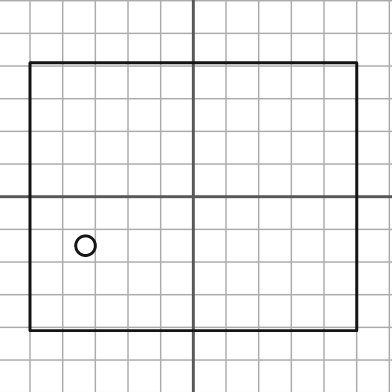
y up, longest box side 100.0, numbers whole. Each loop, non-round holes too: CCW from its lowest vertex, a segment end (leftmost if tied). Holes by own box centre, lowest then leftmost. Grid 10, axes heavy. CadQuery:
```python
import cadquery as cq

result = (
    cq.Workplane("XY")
    .moveTo(-50.0, -41.0)
    .lineTo(50.0, -41.0)
    .lineTo(50.0, 41.0)
    .lineTo(-50.0, 41.0)
    .close()
    .moveTo(-33.0, -15.0)
    .circle(3.0)
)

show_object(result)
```